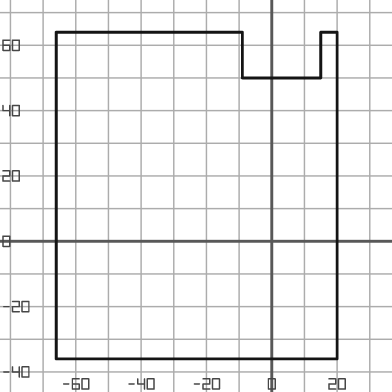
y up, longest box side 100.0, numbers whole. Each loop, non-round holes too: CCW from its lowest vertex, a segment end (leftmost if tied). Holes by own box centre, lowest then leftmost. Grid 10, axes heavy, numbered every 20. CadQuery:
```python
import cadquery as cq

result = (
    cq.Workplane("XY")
    .moveTo(-66.0, -36.0)
    .lineTo(20.0, -36.0)
    .lineTo(20.0, 64.0)
    .lineTo(15.0, 64.0)
    .lineTo(15.0, 50.0)
    .lineTo(-9.0, 50.0)
    .lineTo(-9.0, 64.0)
    .lineTo(-66.0, 64.0)
    .close()
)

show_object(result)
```